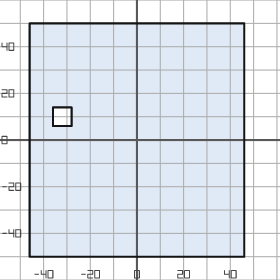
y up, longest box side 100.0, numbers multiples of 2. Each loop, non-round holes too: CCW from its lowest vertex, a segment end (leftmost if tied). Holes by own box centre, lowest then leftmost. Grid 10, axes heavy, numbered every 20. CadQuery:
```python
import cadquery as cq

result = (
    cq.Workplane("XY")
    .moveTo(-46.0, -50.0)
    .lineTo(46.0, -50.0)
    .lineTo(46.0, 50.0)
    .lineTo(-46.0, 50.0)
    .close()
    .moveTo(-36.0, 6.0)
    .lineTo(-28.0, 6.0)
    .lineTo(-28.0, 14.0)
    .lineTo(-36.0, 14.0)
    .close()
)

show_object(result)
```